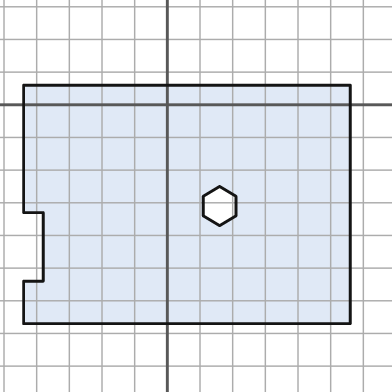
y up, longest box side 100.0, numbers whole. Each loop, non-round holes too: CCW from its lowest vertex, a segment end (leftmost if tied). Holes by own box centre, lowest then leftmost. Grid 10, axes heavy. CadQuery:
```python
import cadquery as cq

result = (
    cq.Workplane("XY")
    .moveTo(-44.0, -67.0)
    .lineTo(56.0, -67.0)
    .lineTo(56.0, 6.0)
    .lineTo(-44.0, 6.0)
    .lineTo(-44.0, -33.0)
    .lineTo(-38.0, -33.0)
    .lineTo(-38.0, -54.0)
    .lineTo(-44.0, -54.0)
    .close()
    .moveTo(16.0, -37.0)
    .lineTo(21.0, -34.0)
    .lineTo(21.0, -28.0)
    .lineTo(16.0, -25.0)
    .lineTo(11.0, -28.0)
    .lineTo(11.0, -34.0)
    .close()
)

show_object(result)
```